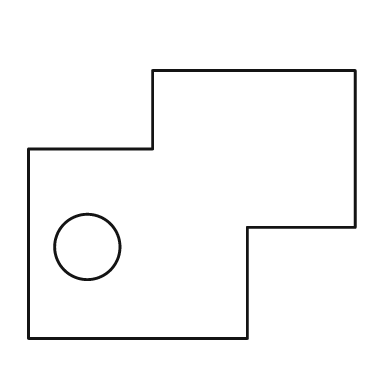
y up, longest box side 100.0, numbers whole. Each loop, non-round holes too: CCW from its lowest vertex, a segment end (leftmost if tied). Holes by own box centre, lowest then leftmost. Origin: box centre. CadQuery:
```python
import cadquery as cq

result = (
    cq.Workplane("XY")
    .moveTo(-50.0, -41.0)
    .lineTo(17.0, -41.0)
    .lineTo(17.0, -7.0)
    .lineTo(50.0, -7.0)
    .lineTo(50.0, 41.0)
    .lineTo(-12.0, 41.0)
    .lineTo(-12.0, 17.0)
    .lineTo(-50.0, 17.0)
    .close()
    .moveTo(-32.0, -13.0)
    .circle(10.0)
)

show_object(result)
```